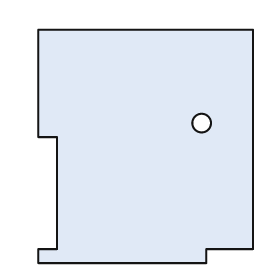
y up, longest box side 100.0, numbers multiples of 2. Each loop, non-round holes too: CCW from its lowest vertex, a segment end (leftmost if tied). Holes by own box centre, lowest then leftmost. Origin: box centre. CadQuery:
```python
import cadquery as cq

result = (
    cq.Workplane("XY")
    .moveTo(-46.0, -50.0)
    .lineTo(26.0, -50.0)
    .lineTo(26.0, -44.0)
    .lineTo(46.0, -44.0)
    .lineTo(46.0, 50.0)
    .lineTo(-46.0, 50.0)
    .lineTo(-46.0, 4.0)
    .lineTo(-38.0, 4.0)
    .lineTo(-38.0, -44.0)
    .lineTo(-46.0, -44.0)
    .close()
    .moveTo(24.0, 10.0)
    .circle(4.0)
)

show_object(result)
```